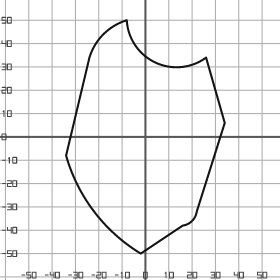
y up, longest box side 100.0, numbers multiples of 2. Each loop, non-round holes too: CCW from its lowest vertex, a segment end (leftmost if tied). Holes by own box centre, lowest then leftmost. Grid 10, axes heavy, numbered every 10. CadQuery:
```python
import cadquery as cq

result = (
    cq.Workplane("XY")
    .moveTo(-2.0, -50.0)
    .lineTo(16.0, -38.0)
    .threePointArc((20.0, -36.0), (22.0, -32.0))
    .lineTo(34.0, 6.0)
    .lineTo(26.0, 34.0)
    .threePointArc((4.0, 32.0), (-8.0, 50.0))
    .threePointArc((-18.0, 44.0), (-24.0, 34.0))
    .lineTo(-34.0, -8.0)
    .threePointArc((-22.0, -32.0), (-2.0, -50.0))
    .close()
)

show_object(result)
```